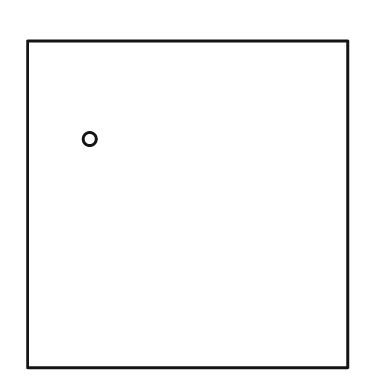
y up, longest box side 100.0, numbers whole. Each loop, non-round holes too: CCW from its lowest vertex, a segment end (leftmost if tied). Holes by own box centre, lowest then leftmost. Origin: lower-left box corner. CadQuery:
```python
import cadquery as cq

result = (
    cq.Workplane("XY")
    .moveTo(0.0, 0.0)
    .lineTo(98.0, 0.0)
    .lineTo(98.0, 100.0)
    .lineTo(0.0, 100.0)
    .close()
    .moveTo(19.0, 70.0)
    .circle(2.0)
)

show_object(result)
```